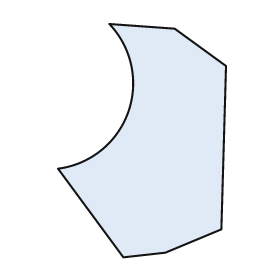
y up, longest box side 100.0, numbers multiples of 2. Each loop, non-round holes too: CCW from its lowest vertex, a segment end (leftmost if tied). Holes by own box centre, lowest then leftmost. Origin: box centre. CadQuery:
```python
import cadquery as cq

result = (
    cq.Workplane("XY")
    .moveTo(-8.0, -50.0)
    .lineTo(10.0, -48.0)
    .lineTo(34.0, -38.0)
    .lineTo(36.0, 32.0)
    .lineTo(14.0, 48.0)
    .lineTo(-14.0, 50.0)
    .threePointArc((-6.0, 12.0), (-36.0, -12.0))
    .close()
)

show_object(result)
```